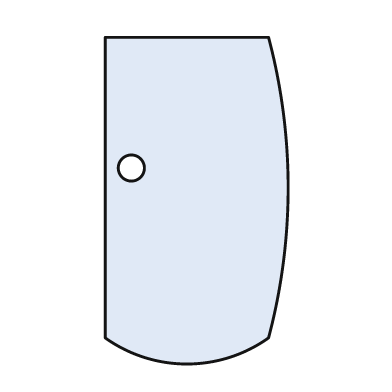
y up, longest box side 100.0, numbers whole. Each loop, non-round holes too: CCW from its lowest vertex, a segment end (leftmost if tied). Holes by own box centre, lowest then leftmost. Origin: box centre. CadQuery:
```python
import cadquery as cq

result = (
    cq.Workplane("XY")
    .moveTo(-28.0, -42.0)
    .threePointArc((-3.0, -50.0), (22.0, -42.0))
    .threePointArc((28.0, 4.0), (22.0, 50.0))
    .lineTo(-28.0, 50.0)
    .close()
    .moveTo(-20.0, 10.0)
    .circle(4.0)
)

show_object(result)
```